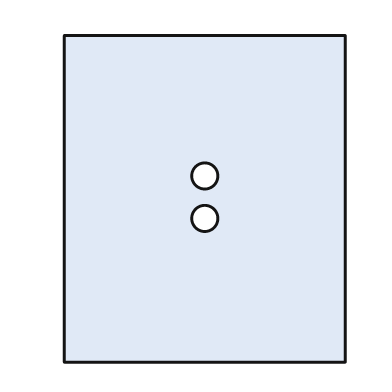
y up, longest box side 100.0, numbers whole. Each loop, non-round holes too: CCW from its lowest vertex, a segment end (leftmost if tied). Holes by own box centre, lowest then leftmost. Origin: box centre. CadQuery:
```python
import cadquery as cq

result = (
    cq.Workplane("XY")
    .moveTo(-43.0, -50.0)
    .lineTo(43.0, -50.0)
    .lineTo(43.0, 50.0)
    .lineTo(-43.0, 50.0)
    .close()
    .moveTo(0.0, -6.0)
    .circle(4.0)
    .moveTo(0.0, 7.0)
    .circle(4.0)
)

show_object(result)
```